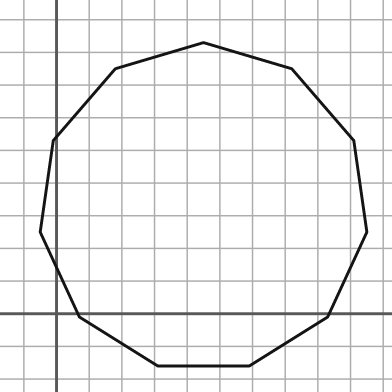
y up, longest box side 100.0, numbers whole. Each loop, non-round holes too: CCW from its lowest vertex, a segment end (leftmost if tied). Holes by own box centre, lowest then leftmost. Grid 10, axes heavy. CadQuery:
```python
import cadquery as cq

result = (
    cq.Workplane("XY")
    .moveTo(31.0, -16.0)
    .lineTo(59.0, -16.0)
    .lineTo(83.0, -1.0)
    .lineTo(95.0, 25.0)
    .lineTo(91.0, 53.0)
    .lineTo(72.0, 75.0)
    .lineTo(45.0, 83.0)
    .lineTo(18.0, 75.0)
    .lineTo(-1.0, 53.0)
    .lineTo(-5.0, 25.0)
    .lineTo(7.0, -1.0)
    .close()
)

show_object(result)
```